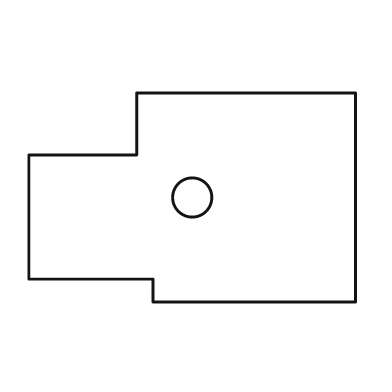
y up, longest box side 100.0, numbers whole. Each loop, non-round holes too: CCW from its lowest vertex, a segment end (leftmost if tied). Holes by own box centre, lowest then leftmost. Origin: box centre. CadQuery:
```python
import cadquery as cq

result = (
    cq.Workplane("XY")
    .moveTo(-12.0, -32.0)
    .lineTo(50.0, -32.0)
    .lineTo(50.0, 32.0)
    .lineTo(-17.0, 32.0)
    .lineTo(-17.0, 13.0)
    .lineTo(-50.0, 13.0)
    .lineTo(-50.0, -25.0)
    .lineTo(-12.0, -25.0)
    .close()
    .moveTo(0.0, 0.0)
    .circle(6.0)
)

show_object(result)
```